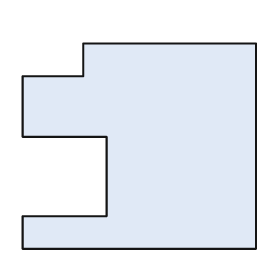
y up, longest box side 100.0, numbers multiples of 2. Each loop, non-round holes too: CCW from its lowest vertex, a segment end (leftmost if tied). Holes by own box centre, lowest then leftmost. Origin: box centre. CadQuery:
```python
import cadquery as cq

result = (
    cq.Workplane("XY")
    .moveTo(-50.0, -44.0)
    .lineTo(50.0, -44.0)
    .lineTo(50.0, 44.0)
    .lineTo(-24.0, 44.0)
    .lineTo(-24.0, 30.0)
    .lineTo(-50.0, 30.0)
    .lineTo(-50.0, 4.0)
    .lineTo(-14.0, 4.0)
    .lineTo(-14.0, -30.0)
    .lineTo(-50.0, -30.0)
    .close()
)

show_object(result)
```